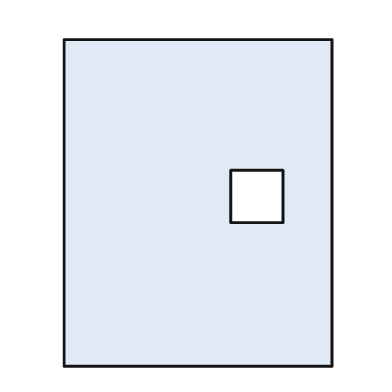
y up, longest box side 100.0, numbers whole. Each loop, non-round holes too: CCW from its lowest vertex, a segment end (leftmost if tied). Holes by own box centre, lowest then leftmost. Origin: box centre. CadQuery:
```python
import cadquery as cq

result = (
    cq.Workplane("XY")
    .moveTo(-41.0, -50.0)
    .lineTo(41.0, -50.0)
    .lineTo(41.0, 50.0)
    .lineTo(-41.0, 50.0)
    .close()
    .moveTo(10.0, -6.0)
    .lineTo(26.0, -6.0)
    .lineTo(26.0, 10.0)
    .lineTo(10.0, 10.0)
    .close()
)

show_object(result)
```